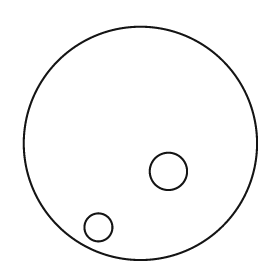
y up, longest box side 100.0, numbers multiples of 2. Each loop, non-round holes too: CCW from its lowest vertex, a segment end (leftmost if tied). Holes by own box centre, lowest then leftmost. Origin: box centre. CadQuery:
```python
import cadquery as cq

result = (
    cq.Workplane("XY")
    .moveTo(0.0, 0.0)
    .circle(50.0)
    .moveTo(-18.0, -36.0)
    .circle(6.0)
    .moveTo(12.0, -12.0)
    .circle(8.0)
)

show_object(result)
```